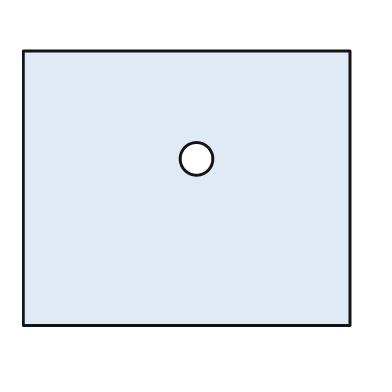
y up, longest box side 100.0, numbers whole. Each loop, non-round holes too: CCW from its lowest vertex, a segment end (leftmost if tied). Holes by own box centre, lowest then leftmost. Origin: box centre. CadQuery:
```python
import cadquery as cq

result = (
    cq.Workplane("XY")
    .moveTo(-50.0, -42.0)
    .lineTo(50.0, -42.0)
    .lineTo(50.0, 42.0)
    .lineTo(-50.0, 42.0)
    .close()
    .moveTo(3.0, 9.0)
    .circle(5.0)
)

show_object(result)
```